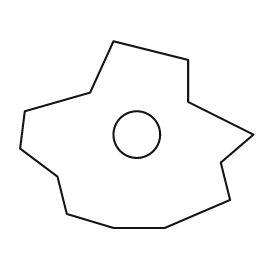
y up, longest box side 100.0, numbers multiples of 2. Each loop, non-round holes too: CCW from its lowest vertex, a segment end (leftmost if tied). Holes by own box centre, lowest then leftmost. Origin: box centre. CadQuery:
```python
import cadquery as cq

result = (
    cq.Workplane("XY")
    .moveTo(-10.0, -40.0)
    .lineTo(12.0, -40.0)
    .lineTo(40.0, -28.0)
    .lineTo(36.0, -12.0)
    .lineTo(50.0, 0.0)
    .lineTo(22.0, 14.0)
    .lineTo(22.0, 32.0)
    .lineTo(-10.0, 40.0)
    .lineTo(-20.0, 18.0)
    .lineTo(-48.0, 10.0)
    .lineTo(-50.0, -6.0)
    .lineTo(-34.0, -18.0)
    .lineTo(-30.0, -34.0)
    .close()
    .moveTo(0.0, 0.0)
    .circle(10.0)
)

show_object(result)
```